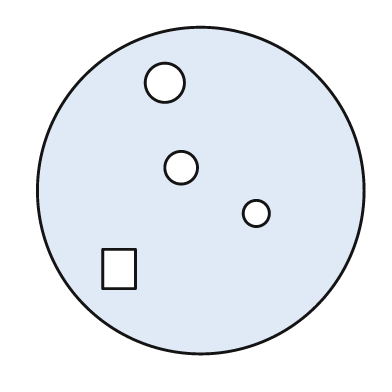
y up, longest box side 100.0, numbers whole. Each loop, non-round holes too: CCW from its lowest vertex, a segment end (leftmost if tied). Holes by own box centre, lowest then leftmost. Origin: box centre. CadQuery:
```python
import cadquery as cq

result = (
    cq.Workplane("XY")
    .moveTo(0.0, 0.0)
    .circle(50.0)
    .moveTo(-30.0, -30.0)
    .lineTo(-20.0, -30.0)
    .lineTo(-20.0, -18.0)
    .lineTo(-30.0, -18.0)
    .close()
    .moveTo(17.0, -7.0)
    .circle(4.0)
    .moveTo(-6.0, 7.0)
    .circle(5.0)
    .moveTo(-11.0, 33.0)
    .circle(6.0)
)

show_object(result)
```